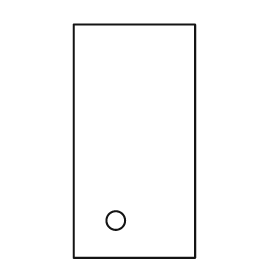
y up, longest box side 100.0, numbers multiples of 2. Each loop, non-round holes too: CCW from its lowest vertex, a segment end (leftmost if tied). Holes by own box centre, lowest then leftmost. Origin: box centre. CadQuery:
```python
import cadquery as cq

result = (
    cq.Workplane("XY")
    .moveTo(-26.0, -50.0)
    .lineTo(26.0, -50.0)
    .lineTo(26.0, 50.0)
    .lineTo(-26.0, 50.0)
    .close()
    .moveTo(-8.0, -34.0)
    .circle(4.0)
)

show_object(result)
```